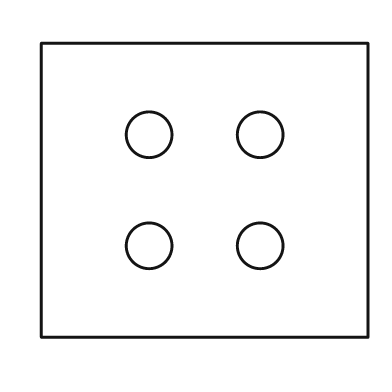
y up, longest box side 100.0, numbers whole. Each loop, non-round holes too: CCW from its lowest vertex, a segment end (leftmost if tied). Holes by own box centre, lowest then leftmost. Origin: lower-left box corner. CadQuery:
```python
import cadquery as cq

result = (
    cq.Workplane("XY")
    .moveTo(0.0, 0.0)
    .lineTo(100.0, 0.0)
    .lineTo(100.0, 90.0)
    .lineTo(0.0, 90.0)
    .close()
    .moveTo(33.0, 28.0)
    .circle(7.0)
    .moveTo(67.0, 28.0)
    .circle(7.0)
    .moveTo(33.0, 62.0)
    .circle(7.0)
    .moveTo(67.0, 62.0)
    .circle(7.0)
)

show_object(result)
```